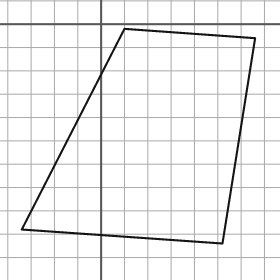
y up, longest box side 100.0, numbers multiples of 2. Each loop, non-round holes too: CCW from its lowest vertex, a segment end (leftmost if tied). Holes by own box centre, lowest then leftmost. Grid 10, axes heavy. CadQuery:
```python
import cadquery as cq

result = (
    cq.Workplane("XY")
    .moveTo(52.0, -94.0)
    .lineTo(66.0, -6.0)
    .lineTo(10.0, -2.0)
    .lineTo(-34.0, -88.0)
    .close()
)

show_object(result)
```